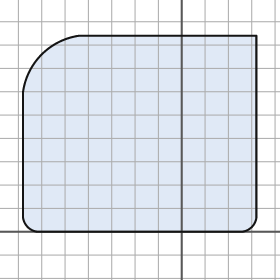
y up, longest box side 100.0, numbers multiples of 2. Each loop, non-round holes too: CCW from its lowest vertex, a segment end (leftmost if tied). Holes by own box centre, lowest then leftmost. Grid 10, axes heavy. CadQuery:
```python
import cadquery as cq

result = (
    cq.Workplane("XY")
    .moveTo(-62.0, 0.0)
    .lineTo(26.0, 0.0)
    .threePointArc((30.0, 2.0), (32.0, 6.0))
    .lineTo(32.0, 84.0)
    .lineTo(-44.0, 84.0)
    .threePointArc((-60.0, 76.0), (-68.0, 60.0))
    .lineTo(-68.0, 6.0)
    .threePointArc((-66.0, 2.0), (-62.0, 0.0))
    .close()
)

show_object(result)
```